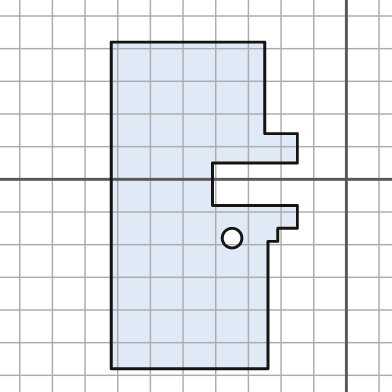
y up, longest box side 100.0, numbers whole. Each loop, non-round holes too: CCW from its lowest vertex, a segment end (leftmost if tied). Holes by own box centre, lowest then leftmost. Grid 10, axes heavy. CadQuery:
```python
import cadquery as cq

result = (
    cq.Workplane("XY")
    .moveTo(-72.0, -58.0)
    .lineTo(-24.0, -58.0)
    .lineTo(-24.0, -19.0)
    .lineTo(-21.0, -19.0)
    .lineTo(-21.0, -15.0)
    .lineTo(-15.0, -15.0)
    .lineTo(-15.0, -8.0)
    .lineTo(-41.0, -8.0)
    .lineTo(-41.0, 5.0)
    .lineTo(-15.0, 5.0)
    .lineTo(-15.0, 14.0)
    .lineTo(-25.0, 14.0)
    .lineTo(-25.0, 42.0)
    .lineTo(-72.0, 42.0)
    .close()
    .moveTo(-35.0, -18.0)
    .circle(3.0)
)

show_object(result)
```